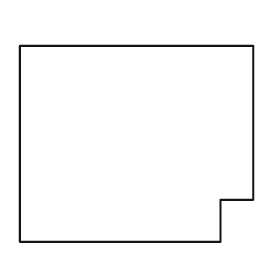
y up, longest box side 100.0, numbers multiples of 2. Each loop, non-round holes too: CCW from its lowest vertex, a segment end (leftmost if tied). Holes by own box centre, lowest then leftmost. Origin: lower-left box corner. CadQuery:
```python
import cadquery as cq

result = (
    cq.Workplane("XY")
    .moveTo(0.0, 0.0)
    .lineTo(86.0, 0.0)
    .lineTo(86.0, 18.0)
    .lineTo(100.0, 18.0)
    .lineTo(100.0, 84.0)
    .lineTo(0.0, 84.0)
    .close()
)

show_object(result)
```